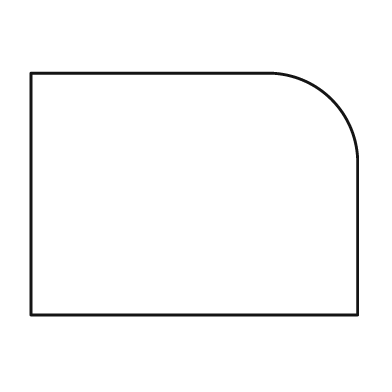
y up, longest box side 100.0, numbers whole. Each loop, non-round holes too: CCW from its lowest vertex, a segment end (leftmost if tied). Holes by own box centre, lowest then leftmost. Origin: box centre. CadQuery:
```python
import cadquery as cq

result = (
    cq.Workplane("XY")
    .moveTo(-50.0, -37.0)
    .lineTo(50.0, -37.0)
    .lineTo(50.0, 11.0)
    .threePointArc((42.0, 29.0), (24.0, 37.0))
    .lineTo(-50.0, 37.0)
    .close()
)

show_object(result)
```